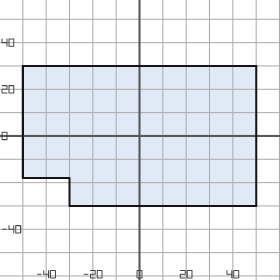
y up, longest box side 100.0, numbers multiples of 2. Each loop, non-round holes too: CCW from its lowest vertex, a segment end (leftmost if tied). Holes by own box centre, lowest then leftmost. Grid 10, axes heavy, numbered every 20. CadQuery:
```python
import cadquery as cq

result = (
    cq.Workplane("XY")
    .moveTo(-30.0, -30.0)
    .lineTo(50.0, -30.0)
    .lineTo(50.0, 30.0)
    .lineTo(-50.0, 30.0)
    .lineTo(-50.0, -18.0)
    .lineTo(-30.0, -18.0)
    .close()
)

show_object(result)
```